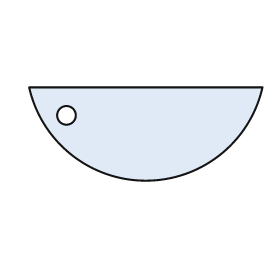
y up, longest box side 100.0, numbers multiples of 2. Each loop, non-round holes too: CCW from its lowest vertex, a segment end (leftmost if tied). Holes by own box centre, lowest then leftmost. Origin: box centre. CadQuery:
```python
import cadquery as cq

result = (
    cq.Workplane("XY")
    .moveTo(-50.0, 20.0)
    .threePointArc((0.0, -20.0), (50.0, 20.0))
    .close()
    .moveTo(-34.0, 8.0)
    .circle(4.0)
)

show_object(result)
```